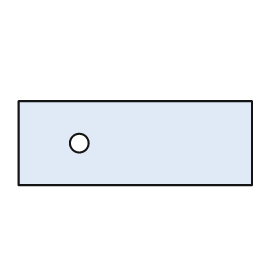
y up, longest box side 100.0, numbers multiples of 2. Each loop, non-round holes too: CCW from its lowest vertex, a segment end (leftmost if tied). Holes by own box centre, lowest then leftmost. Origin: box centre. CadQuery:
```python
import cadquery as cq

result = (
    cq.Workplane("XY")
    .moveTo(-50.0, -18.0)
    .lineTo(50.0, -18.0)
    .lineTo(50.0, 18.0)
    .lineTo(-50.0, 18.0)
    .close()
    .moveTo(-24.0, 0.0)
    .circle(4.0)
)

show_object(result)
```